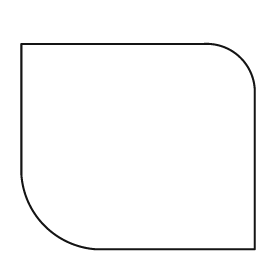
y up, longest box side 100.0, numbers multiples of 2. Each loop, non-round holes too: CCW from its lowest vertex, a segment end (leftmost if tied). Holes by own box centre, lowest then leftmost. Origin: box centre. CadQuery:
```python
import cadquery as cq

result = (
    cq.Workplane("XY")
    .moveTo(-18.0, -44.0)
    .lineTo(50.0, -44.0)
    .lineTo(50.0, 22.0)
    .threePointArc((44.0, 38.0), (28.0, 44.0))
    .lineTo(-50.0, 44.0)
    .lineTo(-50.0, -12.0)
    .threePointArc((-40.0, -34.0), (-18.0, -44.0))
    .close()
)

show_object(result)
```